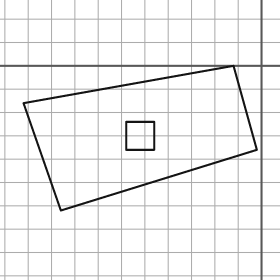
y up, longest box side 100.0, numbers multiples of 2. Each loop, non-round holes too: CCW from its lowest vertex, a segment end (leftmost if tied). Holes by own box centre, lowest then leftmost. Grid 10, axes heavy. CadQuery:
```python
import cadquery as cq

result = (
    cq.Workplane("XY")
    .moveTo(-86.0, -62.0)
    .lineTo(-2.0, -36.0)
    .lineTo(-12.0, 0.0)
    .lineTo(-102.0, -16.0)
    .close()
    .moveTo(-58.0, -36.0)
    .lineTo(-46.0, -36.0)
    .lineTo(-46.0, -24.0)
    .lineTo(-58.0, -24.0)
    .close()
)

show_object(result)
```